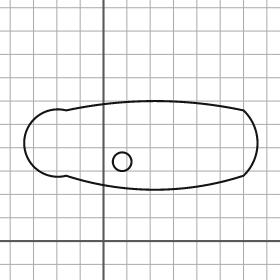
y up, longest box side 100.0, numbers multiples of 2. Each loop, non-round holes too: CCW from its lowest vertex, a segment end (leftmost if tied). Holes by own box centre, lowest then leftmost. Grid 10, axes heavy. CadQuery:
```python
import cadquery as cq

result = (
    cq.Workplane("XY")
    .moveTo(-16.0, 28.0)
    .threePointArc((22.0, 22.0), (60.0, 28.0))
    .threePointArc((66.0, 42.0), (60.0, 56.0))
    .threePointArc((22.0, 60.0), (-16.0, 56.0))
    .threePointArc((-34.0, 42.0), (-16.0, 28.0))
    .close()
    .moveTo(8.0, 34.0)
    .circle(4.0)
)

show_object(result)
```